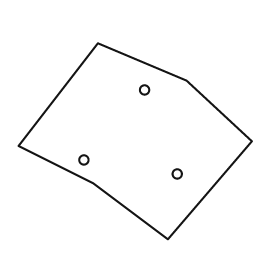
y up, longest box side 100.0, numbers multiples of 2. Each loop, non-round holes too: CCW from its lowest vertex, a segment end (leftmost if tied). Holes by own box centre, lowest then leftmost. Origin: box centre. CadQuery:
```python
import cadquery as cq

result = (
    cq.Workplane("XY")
    .moveTo(14.0, -42.0)
    .lineTo(50.0, 0.0)
    .lineTo(22.0, 26.0)
    .lineTo(-16.0, 42.0)
    .lineTo(-50.0, -2.0)
    .lineTo(-18.0, -18.0)
    .close()
    .moveTo(18.0, -14.0)
    .circle(2.0)
    .moveTo(-22.0, -8.0)
    .circle(2.0)
    .moveTo(4.0, 22.0)
    .circle(2.0)
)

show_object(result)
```